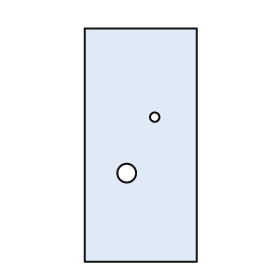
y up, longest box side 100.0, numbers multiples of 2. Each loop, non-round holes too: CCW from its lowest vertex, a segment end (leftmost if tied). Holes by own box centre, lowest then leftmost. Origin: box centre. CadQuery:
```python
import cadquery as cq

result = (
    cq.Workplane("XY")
    .moveTo(-24.0, -50.0)
    .lineTo(24.0, -50.0)
    .lineTo(24.0, 50.0)
    .lineTo(-24.0, 50.0)
    .close()
    .moveTo(-6.0, -12.0)
    .circle(4.0)
    .moveTo(6.0, 12.0)
    .circle(2.0)
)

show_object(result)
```